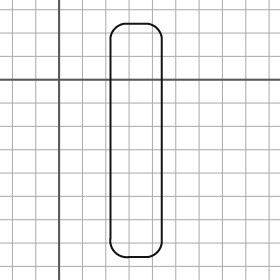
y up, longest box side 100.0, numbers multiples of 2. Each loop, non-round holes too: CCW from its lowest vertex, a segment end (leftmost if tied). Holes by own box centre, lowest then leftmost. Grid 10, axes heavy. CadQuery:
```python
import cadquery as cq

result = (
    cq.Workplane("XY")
    .moveTo(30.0, -76.0)
    .lineTo(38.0, -76.0)
    .threePointArc((42.0, -74.0), (44.0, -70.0))
    .lineTo(44.0, 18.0)
    .threePointArc((42.0, 22.0), (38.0, 24.0))
    .lineTo(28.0, 24.0)
    .threePointArc((24.0, 22.0), (22.0, 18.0))
    .lineTo(22.0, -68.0)
    .threePointArc((24.0, -74.0), (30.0, -76.0))
    .close()
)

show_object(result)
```